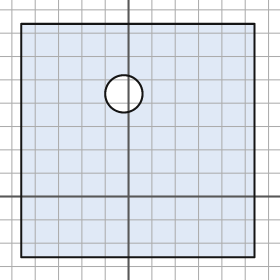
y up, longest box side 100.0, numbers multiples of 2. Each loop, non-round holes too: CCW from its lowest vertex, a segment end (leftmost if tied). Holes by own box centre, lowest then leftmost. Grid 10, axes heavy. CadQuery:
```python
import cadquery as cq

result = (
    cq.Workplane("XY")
    .moveTo(-46.0, -26.0)
    .lineTo(54.0, -26.0)
    .lineTo(54.0, 74.0)
    .lineTo(-46.0, 74.0)
    .close()
    .moveTo(-2.0, 44.0)
    .circle(8.0)
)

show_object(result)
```